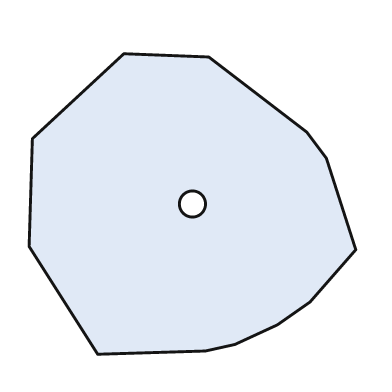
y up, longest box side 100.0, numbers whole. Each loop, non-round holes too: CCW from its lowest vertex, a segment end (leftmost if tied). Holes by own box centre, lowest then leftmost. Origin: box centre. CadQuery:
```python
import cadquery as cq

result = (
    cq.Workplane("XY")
    .moveTo(-29.0, -46.0)
    .lineTo(4.0, -45.0)
    .lineTo(13.0, -43.0)
    .lineTo(26.0, -37.0)
    .lineTo(36.0, -30.0)
    .lineTo(50.0, -14.0)
    .lineTo(41.0, 14.0)
    .lineTo(35.0, 22.0)
    .lineTo(5.0, 45.0)
    .lineTo(-21.0, 46.0)
    .lineTo(-49.0, 20.0)
    .lineTo(-50.0, -13.0)
    .close()
    .moveTo(0.0, 0.0)
    .circle(4.0)
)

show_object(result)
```